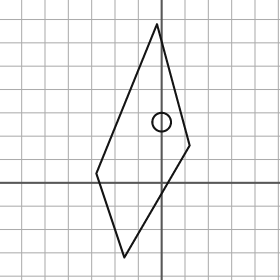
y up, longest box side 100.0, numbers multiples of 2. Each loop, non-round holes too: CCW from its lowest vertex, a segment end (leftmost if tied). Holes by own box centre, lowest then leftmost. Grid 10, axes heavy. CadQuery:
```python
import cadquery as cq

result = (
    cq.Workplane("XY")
    .moveTo(-16.0, -32.0)
    .lineTo(12.0, 16.0)
    .lineTo(-2.0, 68.0)
    .lineTo(-28.0, 4.0)
    .close()
    .moveTo(0.0, 26.0)
    .circle(4.0)
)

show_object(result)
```